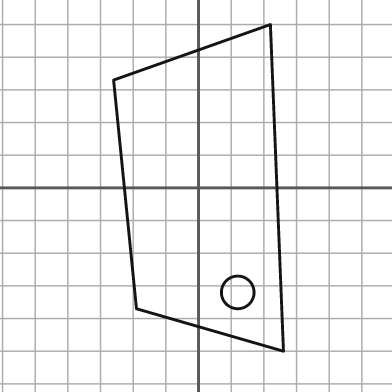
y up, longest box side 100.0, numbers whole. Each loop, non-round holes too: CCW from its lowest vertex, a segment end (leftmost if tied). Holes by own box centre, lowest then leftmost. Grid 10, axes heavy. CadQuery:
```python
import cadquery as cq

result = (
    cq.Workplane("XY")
    .moveTo(26.0, -50.0)
    .lineTo(22.0, 50.0)
    .lineTo(-26.0, 33.0)
    .lineTo(-19.0, -37.0)
    .close()
    .moveTo(12.0, -32.0)
    .circle(5.0)
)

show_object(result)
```